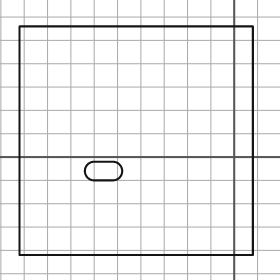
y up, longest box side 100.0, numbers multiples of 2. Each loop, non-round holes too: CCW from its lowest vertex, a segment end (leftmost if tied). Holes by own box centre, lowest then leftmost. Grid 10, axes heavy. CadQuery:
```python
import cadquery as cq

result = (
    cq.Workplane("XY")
    .moveTo(-92.0, -42.0)
    .lineTo(8.0, -42.0)
    .lineTo(8.0, 56.0)
    .lineTo(-92.0, 56.0)
    .close()
    .moveTo(-60.0, -10.0)
    .lineTo(-52.0, -10.0)
    .threePointArc((-48.0, -6.0), (-52.0, -2.0))
    .lineTo(-60.0, -2.0)
    .threePointArc((-64.0, -6.0), (-60.0, -10.0))
    .close()
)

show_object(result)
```